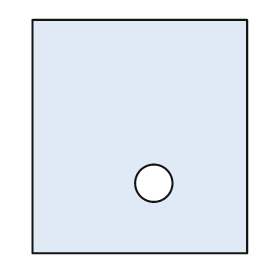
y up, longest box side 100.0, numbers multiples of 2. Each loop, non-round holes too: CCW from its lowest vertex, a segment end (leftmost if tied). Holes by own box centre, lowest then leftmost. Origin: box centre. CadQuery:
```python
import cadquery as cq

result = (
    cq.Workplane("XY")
    .moveTo(-46.0, -50.0)
    .lineTo(46.0, -50.0)
    .lineTo(46.0, 50.0)
    .lineTo(-46.0, 50.0)
    .close()
    .moveTo(6.0, -20.0)
    .circle(8.0)
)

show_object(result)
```